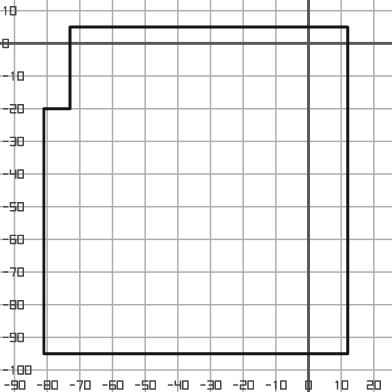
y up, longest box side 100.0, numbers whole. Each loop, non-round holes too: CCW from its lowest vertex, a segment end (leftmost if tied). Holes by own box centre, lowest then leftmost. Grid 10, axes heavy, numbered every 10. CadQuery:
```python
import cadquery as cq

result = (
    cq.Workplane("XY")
    .moveTo(-81.0, -95.0)
    .lineTo(12.0, -95.0)
    .lineTo(12.0, 5.0)
    .lineTo(-73.0, 5.0)
    .lineTo(-73.0, -20.0)
    .lineTo(-81.0, -20.0)
    .close()
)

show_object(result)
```